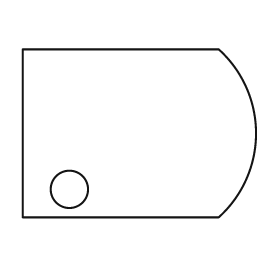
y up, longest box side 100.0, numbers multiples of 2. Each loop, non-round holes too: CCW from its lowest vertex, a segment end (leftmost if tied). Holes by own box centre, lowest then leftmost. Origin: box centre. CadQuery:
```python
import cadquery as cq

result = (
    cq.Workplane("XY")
    .moveTo(-50.0, -36.0)
    .lineTo(34.0, -36.0)
    .threePointArc((50.0, 0.0), (34.0, 36.0))
    .lineTo(-50.0, 36.0)
    .close()
    .moveTo(-30.0, -24.0)
    .circle(8.0)
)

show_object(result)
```